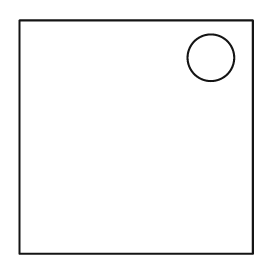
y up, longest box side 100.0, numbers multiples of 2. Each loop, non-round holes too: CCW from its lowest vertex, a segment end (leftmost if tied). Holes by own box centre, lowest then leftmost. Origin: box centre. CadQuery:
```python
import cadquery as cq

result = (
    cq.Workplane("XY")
    .moveTo(-50.0, -50.0)
    .lineTo(50.0, -50.0)
    .lineTo(50.0, 50.0)
    .lineTo(-50.0, 50.0)
    .close()
    .moveTo(32.0, 34.0)
    .circle(10.0)
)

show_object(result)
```